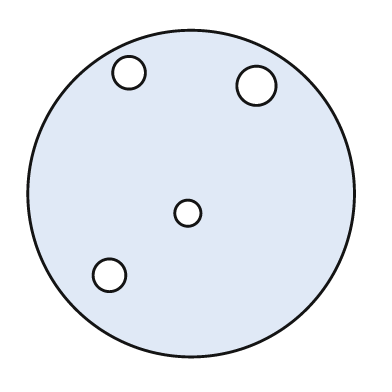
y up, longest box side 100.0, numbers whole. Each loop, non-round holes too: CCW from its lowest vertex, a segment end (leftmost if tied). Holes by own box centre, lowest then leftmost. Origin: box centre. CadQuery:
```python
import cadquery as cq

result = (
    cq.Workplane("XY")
    .moveTo(0.0, 0.0)
    .circle(50.0)
    .moveTo(-25.0, -25.0)
    .circle(5.0)
    .moveTo(-1.0, -6.0)
    .circle(4.0)
    .moveTo(20.0, 33.0)
    .circle(6.0)
    .moveTo(-19.0, 37.0)
    .circle(5.0)
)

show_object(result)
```